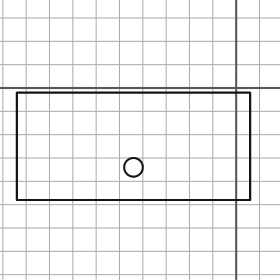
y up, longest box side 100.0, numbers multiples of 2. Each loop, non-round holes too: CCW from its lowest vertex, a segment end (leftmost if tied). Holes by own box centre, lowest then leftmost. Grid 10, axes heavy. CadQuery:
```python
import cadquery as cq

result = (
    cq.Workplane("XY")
    .moveTo(-94.0, -48.0)
    .lineTo(6.0, -48.0)
    .lineTo(6.0, -2.0)
    .lineTo(-94.0, -2.0)
    .close()
    .moveTo(-44.0, -34.0)
    .circle(4.0)
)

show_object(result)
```